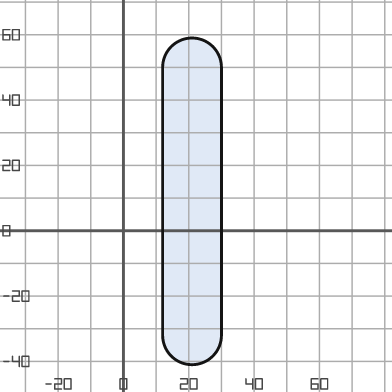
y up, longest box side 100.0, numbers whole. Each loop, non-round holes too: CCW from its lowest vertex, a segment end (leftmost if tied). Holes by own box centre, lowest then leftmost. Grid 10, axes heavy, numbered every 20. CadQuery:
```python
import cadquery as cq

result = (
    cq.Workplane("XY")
    .moveTo(12.0, -32.0)
    .threePointArc((21.0, -41.0), (30.0, -32.0))
    .lineTo(30.0, 50.0)
    .threePointArc((21.0, 59.0), (12.0, 50.0))
    .close()
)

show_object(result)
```